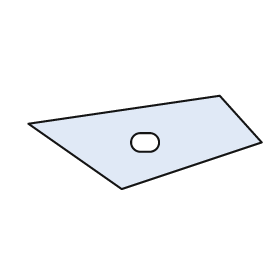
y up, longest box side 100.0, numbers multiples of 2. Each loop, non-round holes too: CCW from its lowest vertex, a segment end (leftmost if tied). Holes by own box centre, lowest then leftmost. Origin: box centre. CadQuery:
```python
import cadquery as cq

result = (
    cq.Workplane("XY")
    .moveTo(-10.0, -20.0)
    .lineTo(50.0, 0.0)
    .lineTo(32.0, 20.0)
    .lineTo(-50.0, 8.0)
    .close()
    .moveTo(-2.0, -4.0)
    .lineTo(2.0, -4.0)
    .threePointArc((6.0, 0.0), (2.0, 4.0))
    .lineTo(-2.0, 4.0)
    .threePointArc((-6.0, 0.0), (-2.0, -4.0))
    .close()
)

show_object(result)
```